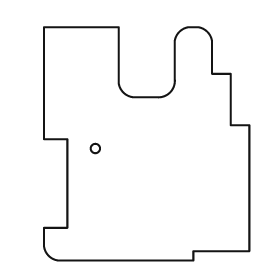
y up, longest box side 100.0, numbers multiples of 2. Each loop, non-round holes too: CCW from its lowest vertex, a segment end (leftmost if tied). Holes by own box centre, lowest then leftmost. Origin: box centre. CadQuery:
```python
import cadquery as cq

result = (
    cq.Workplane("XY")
    .moveTo(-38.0, -50.0)
    .lineTo(20.0, -50.0)
    .lineTo(20.0, -46.0)
    .lineTo(44.0, -46.0)
    .lineTo(44.0, 8.0)
    .lineTo(36.0, 8.0)
    .lineTo(36.0, 30.0)
    .lineTo(28.0, 30.0)
    .lineTo(28.0, 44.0)
    .threePointArc((26.0, 48.0), (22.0, 50.0))
    .lineTo(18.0, 50.0)
    .threePointArc((14.0, 48.0), (12.0, 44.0))
    .lineTo(12.0, 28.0)
    .threePointArc((10.0, 22.0), (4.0, 20.0))
    .lineTo(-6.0, 20.0)
    .threePointArc((-10.0, 22.0), (-12.0, 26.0))
    .lineTo(-12.0, 50.0)
    .lineTo(-44.0, 50.0)
    .lineTo(-44.0, 2.0)
    .lineTo(-34.0, 2.0)
    .lineTo(-34.0, -36.0)
    .lineTo(-44.0, -36.0)
    .lineTo(-44.0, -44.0)
    .threePointArc((-42.0, -48.0), (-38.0, -50.0))
    .close()
    .moveTo(-22.0, -2.0)
    .circle(2.0)
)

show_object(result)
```